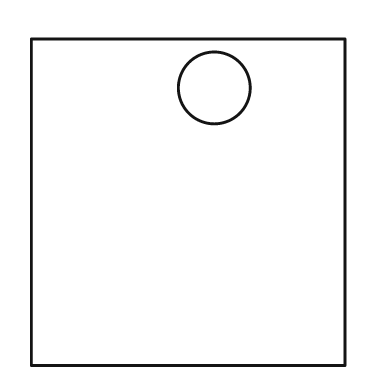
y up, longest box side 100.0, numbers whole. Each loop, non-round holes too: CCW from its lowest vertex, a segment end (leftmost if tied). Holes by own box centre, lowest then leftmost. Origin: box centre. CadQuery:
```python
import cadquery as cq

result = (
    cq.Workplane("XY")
    .moveTo(-48.0, -50.0)
    .lineTo(48.0, -50.0)
    .lineTo(48.0, 50.0)
    .lineTo(-48.0, 50.0)
    .close()
    .moveTo(8.0, 35.0)
    .circle(11.0)
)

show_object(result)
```